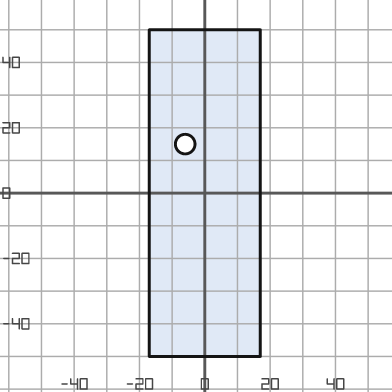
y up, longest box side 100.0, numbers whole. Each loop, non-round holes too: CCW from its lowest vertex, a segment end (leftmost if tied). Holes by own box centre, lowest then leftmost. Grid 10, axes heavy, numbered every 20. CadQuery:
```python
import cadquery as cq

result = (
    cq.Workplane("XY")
    .moveTo(-17.0, -50.0)
    .lineTo(17.0, -50.0)
    .lineTo(17.0, 50.0)
    .lineTo(-17.0, 50.0)
    .close()
    .moveTo(-6.0, 15.0)
    .circle(3.0)
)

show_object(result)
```